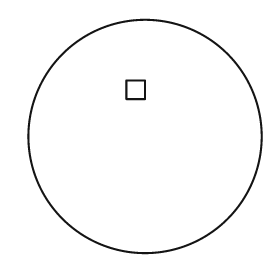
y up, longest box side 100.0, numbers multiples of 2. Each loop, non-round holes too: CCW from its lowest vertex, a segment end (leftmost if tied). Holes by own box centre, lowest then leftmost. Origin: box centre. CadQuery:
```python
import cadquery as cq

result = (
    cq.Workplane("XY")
    .moveTo(0.0, 0.0)
    .circle(50.0)
    .moveTo(-8.0, 16.0)
    .lineTo(0.0, 16.0)
    .lineTo(0.0, 24.0)
    .lineTo(-8.0, 24.0)
    .close()
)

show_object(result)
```